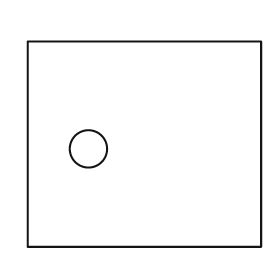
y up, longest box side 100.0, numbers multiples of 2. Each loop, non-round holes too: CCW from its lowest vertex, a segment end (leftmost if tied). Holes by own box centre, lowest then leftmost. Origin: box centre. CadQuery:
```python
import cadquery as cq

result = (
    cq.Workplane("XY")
    .moveTo(-50.0, -44.0)
    .lineTo(50.0, -44.0)
    .lineTo(50.0, 44.0)
    .lineTo(-50.0, 44.0)
    .close()
    .moveTo(-24.0, -2.0)
    .circle(8.0)
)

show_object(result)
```